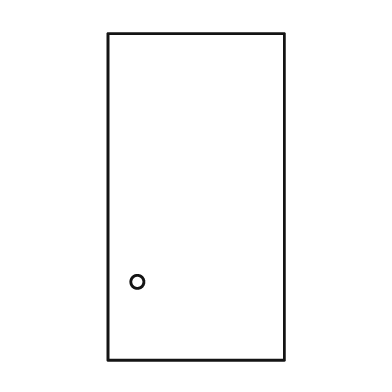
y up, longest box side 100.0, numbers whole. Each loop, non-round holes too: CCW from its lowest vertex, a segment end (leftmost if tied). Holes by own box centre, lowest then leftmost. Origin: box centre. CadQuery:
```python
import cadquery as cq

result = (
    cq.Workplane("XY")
    .moveTo(-27.0, -50.0)
    .lineTo(27.0, -50.0)
    .lineTo(27.0, 50.0)
    .lineTo(-27.0, 50.0)
    .close()
    .moveTo(-18.0, -26.0)
    .circle(2.0)
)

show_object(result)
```